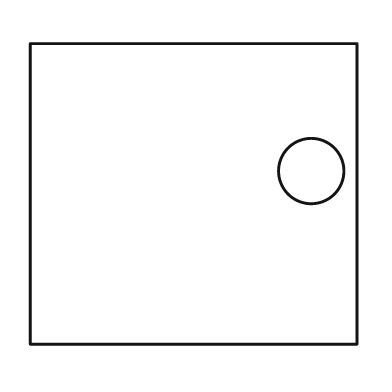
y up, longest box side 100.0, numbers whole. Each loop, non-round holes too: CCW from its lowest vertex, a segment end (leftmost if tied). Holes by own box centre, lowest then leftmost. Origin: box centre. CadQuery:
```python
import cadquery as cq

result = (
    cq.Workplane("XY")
    .moveTo(-50.0, -46.0)
    .lineTo(50.0, -46.0)
    .lineTo(50.0, 46.0)
    .lineTo(-50.0, 46.0)
    .close()
    .moveTo(36.0, 7.0)
    .circle(10.0)
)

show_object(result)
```